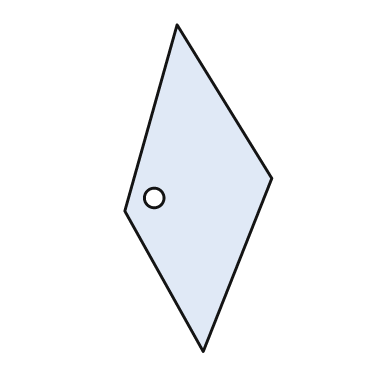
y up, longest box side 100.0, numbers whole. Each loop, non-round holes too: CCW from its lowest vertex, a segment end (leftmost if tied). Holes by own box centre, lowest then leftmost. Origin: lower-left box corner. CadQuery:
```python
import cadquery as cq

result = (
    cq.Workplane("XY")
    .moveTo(24.0, 0.0)
    .lineTo(45.0, 53.0)
    .lineTo(16.0, 100.0)
    .lineTo(0.0, 43.0)
    .close()
    .moveTo(9.0, 47.0)
    .circle(3.0)
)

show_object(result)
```